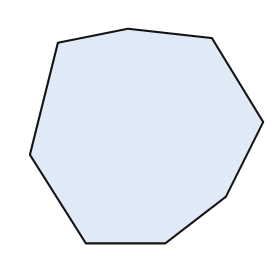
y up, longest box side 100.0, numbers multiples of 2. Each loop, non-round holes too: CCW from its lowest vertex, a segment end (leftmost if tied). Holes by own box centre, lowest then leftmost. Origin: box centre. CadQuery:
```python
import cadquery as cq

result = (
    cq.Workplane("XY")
    .moveTo(-26.0, -46.0)
    .lineTo(8.0, -46.0)
    .lineTo(34.0, -26.0)
    .lineTo(50.0, 6.0)
    .lineTo(28.0, 42.0)
    .lineTo(-8.0, 46.0)
    .lineTo(-38.0, 40.0)
    .lineTo(-50.0, -8.0)
    .close()
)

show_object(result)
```